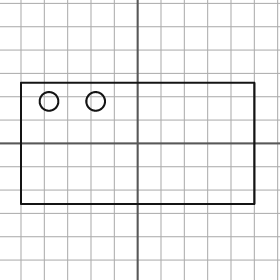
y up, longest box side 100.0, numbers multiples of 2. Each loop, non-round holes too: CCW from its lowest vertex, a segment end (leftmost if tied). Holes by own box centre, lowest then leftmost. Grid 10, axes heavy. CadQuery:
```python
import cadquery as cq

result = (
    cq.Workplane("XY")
    .moveTo(-50.0, -26.0)
    .lineTo(50.0, -26.0)
    .lineTo(50.0, 26.0)
    .lineTo(-50.0, 26.0)
    .close()
    .moveTo(-38.0, 18.0)
    .circle(4.0)
    .moveTo(-18.0, 18.0)
    .circle(4.0)
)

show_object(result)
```